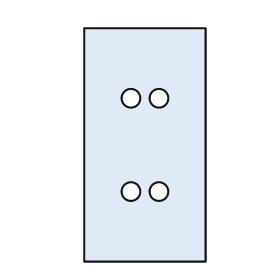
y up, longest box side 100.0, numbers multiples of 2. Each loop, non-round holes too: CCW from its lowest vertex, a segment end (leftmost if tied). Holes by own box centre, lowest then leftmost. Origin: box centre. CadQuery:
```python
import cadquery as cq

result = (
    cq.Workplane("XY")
    .moveTo(-26.0, -50.0)
    .lineTo(26.0, -50.0)
    .lineTo(26.0, 50.0)
    .lineTo(-26.0, 50.0)
    .close()
    .moveTo(-6.0, -20.0)
    .circle(4.0)
    .moveTo(6.0, -20.0)
    .circle(4.0)
    .moveTo(-6.0, 20.0)
    .circle(4.0)
    .moveTo(6.0, 20.0)
    .circle(4.0)
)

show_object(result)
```